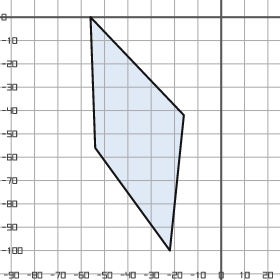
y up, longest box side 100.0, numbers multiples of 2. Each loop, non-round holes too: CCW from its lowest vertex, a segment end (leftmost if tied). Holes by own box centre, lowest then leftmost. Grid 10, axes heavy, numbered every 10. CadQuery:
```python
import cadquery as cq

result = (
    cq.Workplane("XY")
    .moveTo(-22.0, -100.0)
    .lineTo(-16.0, -42.0)
    .lineTo(-56.0, 0.0)
    .lineTo(-54.0, -56.0)
    .close()
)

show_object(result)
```